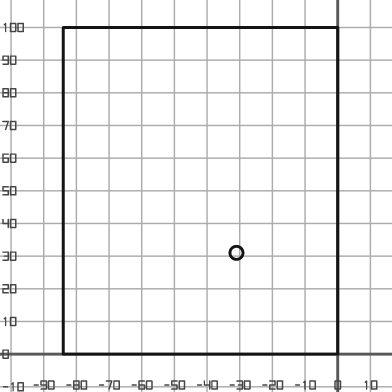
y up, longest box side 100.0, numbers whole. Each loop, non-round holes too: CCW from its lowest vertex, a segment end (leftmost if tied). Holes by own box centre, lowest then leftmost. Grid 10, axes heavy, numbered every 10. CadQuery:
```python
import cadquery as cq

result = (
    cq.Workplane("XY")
    .moveTo(-84.0, 0.0)
    .lineTo(0.0, 0.0)
    .lineTo(0.0, 100.0)
    .lineTo(-84.0, 100.0)
    .close()
    .moveTo(-31.0, 31.0)
    .circle(2.0)
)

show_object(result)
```